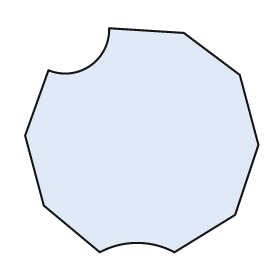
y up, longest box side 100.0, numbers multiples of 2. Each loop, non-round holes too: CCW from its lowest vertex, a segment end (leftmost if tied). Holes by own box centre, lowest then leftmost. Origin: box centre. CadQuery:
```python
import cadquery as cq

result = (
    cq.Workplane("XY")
    .moveTo(-18.0, -48.0)
    .threePointArc((-2.0, -44.0), (14.0, -48.0))
    .lineTo(40.0, -32.0)
    .lineTo(50.0, -2.0)
    .lineTo(42.0, 28.0)
    .lineTo(18.0, 46.0)
    .lineTo(-14.0, 48.0)
    .threePointArc((-22.0, 32.0), (-40.0, 30.0))
    .lineTo(-50.0, 2.0)
    .lineTo(-42.0, -28.0)
    .close()
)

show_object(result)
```